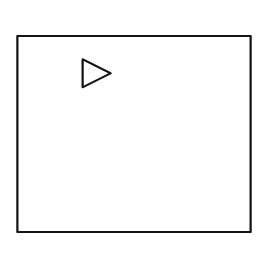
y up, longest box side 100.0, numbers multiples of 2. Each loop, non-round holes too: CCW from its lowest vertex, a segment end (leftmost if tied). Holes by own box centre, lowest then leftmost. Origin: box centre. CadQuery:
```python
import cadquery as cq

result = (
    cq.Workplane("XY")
    .moveTo(-50.0, -42.0)
    .lineTo(50.0, -42.0)
    .lineTo(50.0, 42.0)
    .lineTo(-50.0, 42.0)
    .close()
    .moveTo(-22.0, 20.0)
    .lineTo(-10.0, 26.0)
    .lineTo(-22.0, 32.0)
    .close()
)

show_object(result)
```